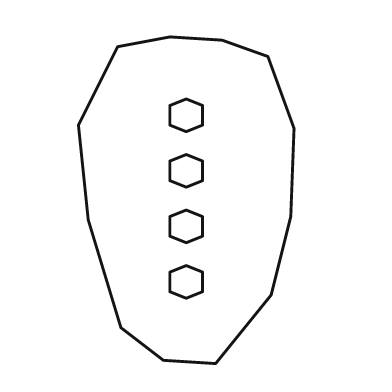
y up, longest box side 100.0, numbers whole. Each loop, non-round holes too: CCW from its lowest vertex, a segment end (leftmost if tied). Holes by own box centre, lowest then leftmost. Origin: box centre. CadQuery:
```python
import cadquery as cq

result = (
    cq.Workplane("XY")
    .moveTo(9.0, -50.0)
    .lineTo(26.0, -29.0)
    .lineTo(32.0, -5.0)
    .lineTo(33.0, 22.0)
    .lineTo(25.0, 44.0)
    .lineTo(11.0, 49.0)
    .lineTo(-5.0, 50.0)
    .lineTo(-21.0, 47.0)
    .lineTo(-33.0, 23.0)
    .lineTo(-30.0, -6.0)
    .lineTo(-20.0, -39.0)
    .lineTo(-7.0, -49.0)
    .close()
    .moveTo(0.0, -30.0)
    .lineTo(5.0, -28.0)
    .lineTo(5.0, -22.0)
    .lineTo(0.0, -20.0)
    .lineTo(-5.0, -22.0)
    .lineTo(-5.0, -28.0)
    .close()
    .moveTo(0.0, -13.0)
    .lineTo(5.0, -11.0)
    .lineTo(5.0, -5.0)
    .lineTo(0.0, -3.0)
    .lineTo(-5.0, -5.0)
    .lineTo(-5.0, -11.0)
    .close()
    .moveTo(0.0, 4.0)
    .lineTo(5.0, 6.0)
    .lineTo(5.0, 12.0)
    .lineTo(0.0, 14.0)
    .lineTo(-5.0, 12.0)
    .lineTo(-5.0, 6.0)
    .close()
    .moveTo(0.0, 21.0)
    .lineTo(5.0, 23.0)
    .lineTo(5.0, 29.0)
    .lineTo(0.0, 31.0)
    .lineTo(-5.0, 29.0)
    .lineTo(-5.0, 23.0)
    .close()
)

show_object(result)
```